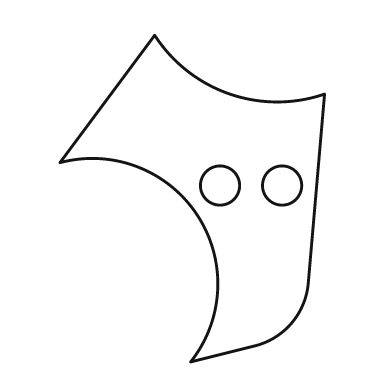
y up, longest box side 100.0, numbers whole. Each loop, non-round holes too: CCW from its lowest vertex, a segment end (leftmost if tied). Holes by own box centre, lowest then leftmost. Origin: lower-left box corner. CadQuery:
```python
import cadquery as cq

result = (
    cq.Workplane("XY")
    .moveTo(40.0, 0.0)
    .lineTo(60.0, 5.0)
    .threePointArc((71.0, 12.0), (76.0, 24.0))
    .lineTo(81.0, 82.0)
    .threePointArc((52.0, 82.0), (29.0, 100.0))
    .lineTo(0.0, 61.0)
    .threePointArc((42.0, 45.0), (40.0, 0.0))
    .close()
    .moveTo(49.0, 54.0)
    .circle(6.0)
    .moveTo(68.0, 54.0)
    .circle(6.0)
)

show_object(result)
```